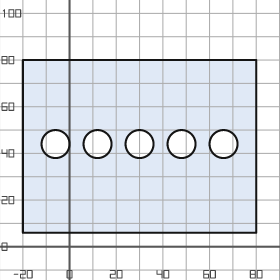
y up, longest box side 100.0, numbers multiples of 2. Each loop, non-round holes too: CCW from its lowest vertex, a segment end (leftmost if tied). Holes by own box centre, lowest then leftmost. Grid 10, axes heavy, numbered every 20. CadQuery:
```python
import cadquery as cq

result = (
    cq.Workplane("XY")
    .moveTo(-20.0, 6.0)
    .lineTo(80.0, 6.0)
    .lineTo(80.0, 80.0)
    .lineTo(-20.0, 80.0)
    .close()
    .moveTo(-6.0, 44.0)
    .circle(6.0)
    .moveTo(12.0, 44.0)
    .circle(6.0)
    .moveTo(30.0, 44.0)
    .circle(6.0)
    .moveTo(48.0, 44.0)
    .circle(6.0)
    .moveTo(66.0, 44.0)
    .circle(6.0)
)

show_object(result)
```